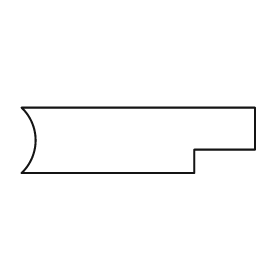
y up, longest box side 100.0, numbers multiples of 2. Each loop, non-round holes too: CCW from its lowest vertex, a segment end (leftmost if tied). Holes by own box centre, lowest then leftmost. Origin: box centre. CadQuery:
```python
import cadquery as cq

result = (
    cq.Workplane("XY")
    .moveTo(-50.0, -14.0)
    .lineTo(24.0, -14.0)
    .lineTo(24.0, -4.0)
    .lineTo(50.0, -4.0)
    .lineTo(50.0, 14.0)
    .lineTo(-50.0, 14.0)
    .threePointArc((-44.0, 0.0), (-50.0, -14.0))
    .close()
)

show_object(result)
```